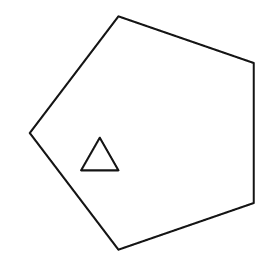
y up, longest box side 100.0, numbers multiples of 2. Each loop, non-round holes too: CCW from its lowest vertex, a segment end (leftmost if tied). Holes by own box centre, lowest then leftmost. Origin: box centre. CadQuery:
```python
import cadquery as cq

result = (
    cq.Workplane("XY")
    .moveTo(-10.0, -50.0)
    .lineTo(48.0, -30.0)
    .lineTo(48.0, 30.0)
    .lineTo(-10.0, 50.0)
    .lineTo(-48.0, 0.0)
    .close()
    .moveTo(-26.0, -16.0)
    .lineTo(-10.0, -16.0)
    .lineTo(-18.0, -2.0)
    .close()
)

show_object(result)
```